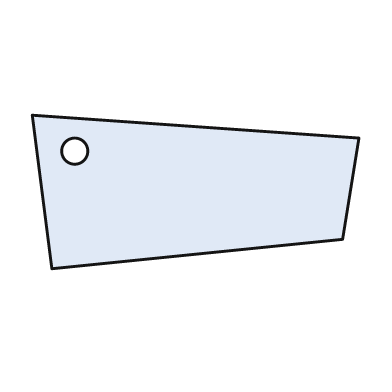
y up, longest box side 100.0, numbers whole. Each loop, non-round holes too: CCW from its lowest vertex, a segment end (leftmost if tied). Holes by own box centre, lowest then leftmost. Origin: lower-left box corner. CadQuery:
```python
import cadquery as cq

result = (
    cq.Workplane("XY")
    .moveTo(6.0, 0.0)
    .lineTo(95.0, 9.0)
    .lineTo(100.0, 40.0)
    .lineTo(0.0, 47.0)
    .close()
    .moveTo(13.0, 36.0)
    .circle(4.0)
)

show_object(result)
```